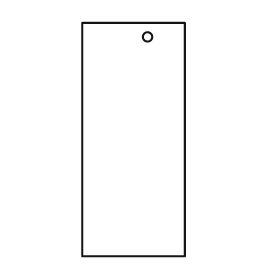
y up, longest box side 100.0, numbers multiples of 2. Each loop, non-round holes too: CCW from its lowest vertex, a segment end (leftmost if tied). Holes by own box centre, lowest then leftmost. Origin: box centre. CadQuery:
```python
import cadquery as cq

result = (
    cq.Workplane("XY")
    .moveTo(-22.0, -50.0)
    .lineTo(22.0, -50.0)
    .lineTo(22.0, 50.0)
    .lineTo(-22.0, 50.0)
    .close()
    .moveTo(6.0, 44.0)
    .circle(2.0)
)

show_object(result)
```